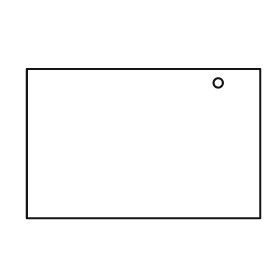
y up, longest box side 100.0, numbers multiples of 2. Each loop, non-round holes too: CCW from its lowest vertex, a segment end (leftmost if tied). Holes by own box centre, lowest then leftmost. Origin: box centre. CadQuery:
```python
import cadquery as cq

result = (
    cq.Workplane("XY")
    .moveTo(-50.0, -32.0)
    .lineTo(50.0, -32.0)
    .lineTo(50.0, 32.0)
    .lineTo(-50.0, 32.0)
    .close()
    .moveTo(32.0, 26.0)
    .circle(2.0)
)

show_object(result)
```